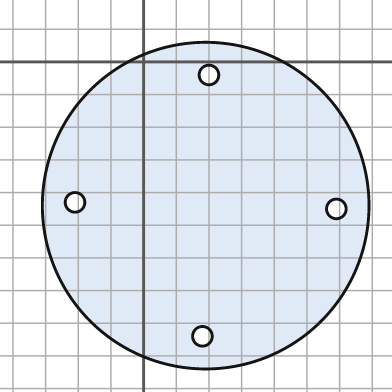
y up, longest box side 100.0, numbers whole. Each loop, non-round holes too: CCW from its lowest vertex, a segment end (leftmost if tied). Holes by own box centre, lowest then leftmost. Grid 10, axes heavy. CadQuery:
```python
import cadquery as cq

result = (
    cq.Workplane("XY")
    .moveTo(19.0, -44.0)
    .circle(50.0)
    .moveTo(18.0, -84.0)
    .circle(3.0)
    .moveTo(59.0, -45.0)
    .circle(3.0)
    .moveTo(-21.0, -43.0)
    .circle(3.0)
    .moveTo(20.0, -4.0)
    .circle(3.0)
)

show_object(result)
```